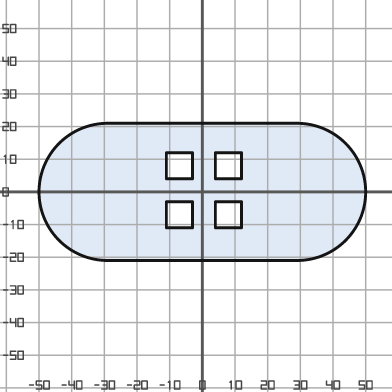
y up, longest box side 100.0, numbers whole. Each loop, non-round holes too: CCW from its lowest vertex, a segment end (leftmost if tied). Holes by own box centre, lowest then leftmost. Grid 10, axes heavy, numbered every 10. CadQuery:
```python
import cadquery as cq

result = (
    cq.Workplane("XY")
    .moveTo(-29.0, -21.0)
    .lineTo(29.0, -21.0)
    .threePointArc((50.0, 0.0), (29.0, 21.0))
    .lineTo(-29.0, 21.0)
    .threePointArc((-50.0, 0.0), (-29.0, -21.0))
    .close()
    .moveTo(-11.0, -11.0)
    .lineTo(-3.0, -11.0)
    .lineTo(-3.0, -3.0)
    .lineTo(-11.0, -3.0)
    .close()
    .moveTo(4.0, -11.0)
    .lineTo(12.0, -11.0)
    .lineTo(12.0, -3.0)
    .lineTo(4.0, -3.0)
    .close()
    .moveTo(-11.0, 4.0)
    .lineTo(-3.0, 4.0)
    .lineTo(-3.0, 12.0)
    .lineTo(-11.0, 12.0)
    .close()
    .moveTo(4.0, 4.0)
    .lineTo(12.0, 4.0)
    .lineTo(12.0, 12.0)
    .lineTo(4.0, 12.0)
    .close()
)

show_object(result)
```